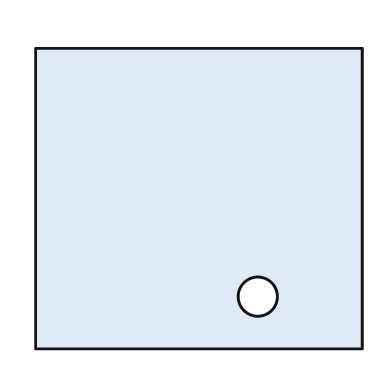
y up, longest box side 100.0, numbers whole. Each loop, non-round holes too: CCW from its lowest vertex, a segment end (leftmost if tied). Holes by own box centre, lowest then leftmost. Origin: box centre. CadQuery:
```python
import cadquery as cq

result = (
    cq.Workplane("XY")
    .moveTo(-50.0, -46.0)
    .lineTo(50.0, -46.0)
    .lineTo(50.0, 46.0)
    .lineTo(-50.0, 46.0)
    .close()
    .moveTo(18.0, -30.0)
    .circle(6.0)
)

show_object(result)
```